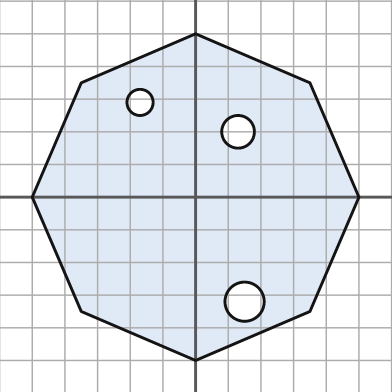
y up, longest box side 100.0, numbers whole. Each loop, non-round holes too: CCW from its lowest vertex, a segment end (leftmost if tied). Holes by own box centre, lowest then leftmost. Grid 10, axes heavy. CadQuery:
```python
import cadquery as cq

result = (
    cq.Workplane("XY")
    .moveTo(0.0, -50.0)
    .lineTo(35.0, -35.0)
    .lineTo(50.0, 0.0)
    .lineTo(35.0, 35.0)
    .lineTo(0.0, 50.0)
    .lineTo(-35.0, 35.0)
    .lineTo(-50.0, 0.0)
    .lineTo(-35.0, -35.0)
    .close()
    .moveTo(15.0, -32.0)
    .circle(6.0)
    .moveTo(13.0, 20.0)
    .circle(5.0)
    .moveTo(-17.0, 29.0)
    .circle(4.0)
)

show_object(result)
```